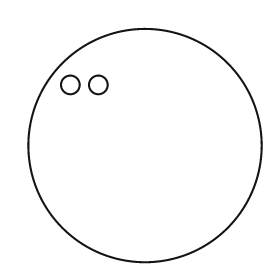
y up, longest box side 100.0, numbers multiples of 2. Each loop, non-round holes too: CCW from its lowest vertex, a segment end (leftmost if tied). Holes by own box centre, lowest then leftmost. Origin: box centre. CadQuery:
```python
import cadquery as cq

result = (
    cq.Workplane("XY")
    .moveTo(0.0, 0.0)
    .circle(50.0)
    .moveTo(-32.0, 26.0)
    .circle(4.0)
    .moveTo(-20.0, 26.0)
    .circle(4.0)
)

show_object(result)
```